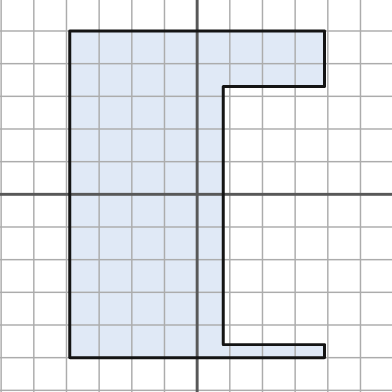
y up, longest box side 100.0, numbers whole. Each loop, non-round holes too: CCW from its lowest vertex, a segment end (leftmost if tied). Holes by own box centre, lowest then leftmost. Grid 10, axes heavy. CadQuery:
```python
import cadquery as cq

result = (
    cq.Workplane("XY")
    .moveTo(-39.0, -50.0)
    .lineTo(39.0, -50.0)
    .lineTo(39.0, -46.0)
    .lineTo(8.0, -46.0)
    .lineTo(8.0, 33.0)
    .lineTo(39.0, 33.0)
    .lineTo(39.0, 50.0)
    .lineTo(-39.0, 50.0)
    .close()
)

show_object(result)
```